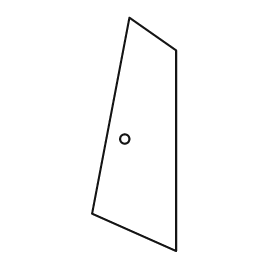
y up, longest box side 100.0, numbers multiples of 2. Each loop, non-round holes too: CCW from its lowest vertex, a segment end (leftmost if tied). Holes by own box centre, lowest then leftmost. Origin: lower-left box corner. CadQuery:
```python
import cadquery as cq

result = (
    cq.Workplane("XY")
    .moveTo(36.0, 0.0)
    .lineTo(36.0, 86.0)
    .lineTo(16.0, 100.0)
    .lineTo(0.0, 16.0)
    .close()
    .moveTo(14.0, 48.0)
    .circle(2.0)
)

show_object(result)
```